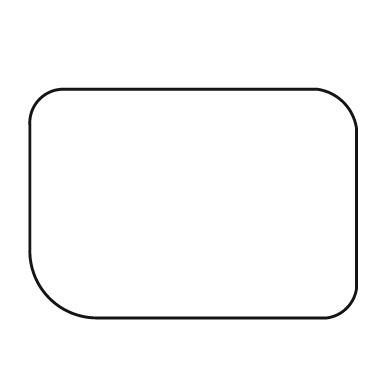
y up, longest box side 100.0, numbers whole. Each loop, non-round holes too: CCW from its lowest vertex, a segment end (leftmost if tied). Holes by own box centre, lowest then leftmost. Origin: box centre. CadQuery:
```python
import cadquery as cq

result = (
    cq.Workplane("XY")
    .moveTo(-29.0, -35.0)
    .lineTo(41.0, -35.0)
    .threePointArc((47.0, -32.0), (50.0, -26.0))
    .lineTo(50.0, 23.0)
    .threePointArc((46.0, 31.0), (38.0, 35.0))
    .lineTo(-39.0, 35.0)
    .threePointArc((-47.0, 32.0), (-50.0, 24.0))
    .lineTo(-50.0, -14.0)
    .threePointArc((-44.0, -29.0), (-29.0, -35.0))
    .close()
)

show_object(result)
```